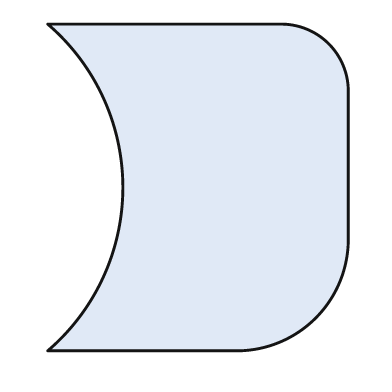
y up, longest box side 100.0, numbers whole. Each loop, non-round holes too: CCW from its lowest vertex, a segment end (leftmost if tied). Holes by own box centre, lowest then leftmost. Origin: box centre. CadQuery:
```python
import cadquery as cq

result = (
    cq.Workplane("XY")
    .moveTo(-46.0, -50.0)
    .lineTo(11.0, -50.0)
    .threePointArc((36.0, -40.0), (46.0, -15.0))
    .lineTo(46.0, 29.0)
    .threePointArc((40.0, 44.0), (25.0, 50.0))
    .lineTo(-46.0, 50.0)
    .threePointArc((-23.0, 0.0), (-46.0, -50.0))
    .close()
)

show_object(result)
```